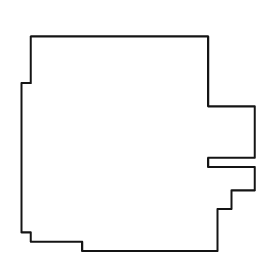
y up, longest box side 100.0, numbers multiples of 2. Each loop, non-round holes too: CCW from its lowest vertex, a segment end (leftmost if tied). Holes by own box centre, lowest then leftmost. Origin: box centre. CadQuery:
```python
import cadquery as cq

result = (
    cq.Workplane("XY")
    .moveTo(-24.0, -46.0)
    .lineTo(34.0, -46.0)
    .lineTo(34.0, -28.0)
    .lineTo(40.0, -28.0)
    .lineTo(40.0, -20.0)
    .lineTo(50.0, -20.0)
    .lineTo(50.0, -10.0)
    .lineTo(30.0, -10.0)
    .lineTo(30.0, -6.0)
    .lineTo(50.0, -6.0)
    .lineTo(50.0, 16.0)
    .lineTo(30.0, 16.0)
    .lineTo(30.0, 46.0)
    .lineTo(-46.0, 46.0)
    .lineTo(-46.0, 26.0)
    .lineTo(-50.0, 26.0)
    .lineTo(-50.0, -38.0)
    .lineTo(-46.0, -38.0)
    .lineTo(-46.0, -42.0)
    .lineTo(-24.0, -42.0)
    .close()
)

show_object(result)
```